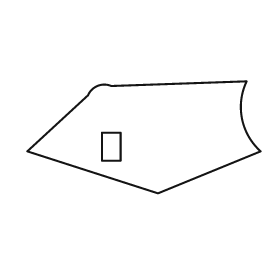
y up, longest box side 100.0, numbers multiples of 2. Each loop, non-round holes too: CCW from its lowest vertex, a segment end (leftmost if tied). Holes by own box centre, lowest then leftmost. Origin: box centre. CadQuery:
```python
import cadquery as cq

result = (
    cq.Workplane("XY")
    .moveTo(6.0, -24.0)
    .lineTo(50.0, -6.0)
    .threePointArc((42.0, 8.0), (44.0, 24.0))
    .lineTo(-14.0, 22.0)
    .threePointArc((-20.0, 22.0), (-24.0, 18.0))
    .lineTo(-50.0, -6.0)
    .close()
    .moveTo(-18.0, -10.0)
    .lineTo(-10.0, -10.0)
    .lineTo(-10.0, 2.0)
    .lineTo(-18.0, 2.0)
    .close()
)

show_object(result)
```